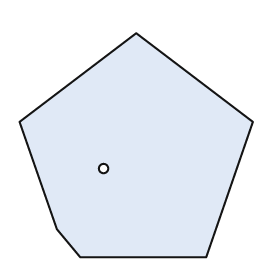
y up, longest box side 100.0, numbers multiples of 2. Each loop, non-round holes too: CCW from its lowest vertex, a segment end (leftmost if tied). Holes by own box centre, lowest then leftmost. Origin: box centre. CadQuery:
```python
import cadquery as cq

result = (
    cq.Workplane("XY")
    .moveTo(-24.0, -48.0)
    .lineTo(30.0, -48.0)
    .lineTo(50.0, 10.0)
    .lineTo(0.0, 48.0)
    .lineTo(-50.0, 10.0)
    .lineTo(-34.0, -36.0)
    .close()
    .moveTo(-14.0, -10.0)
    .circle(2.0)
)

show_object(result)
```